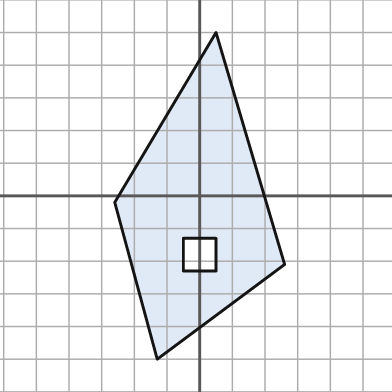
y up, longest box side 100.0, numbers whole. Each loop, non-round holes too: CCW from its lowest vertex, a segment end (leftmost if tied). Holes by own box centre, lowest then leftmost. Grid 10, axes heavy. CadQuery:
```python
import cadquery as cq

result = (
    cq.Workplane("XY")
    .moveTo(-13.0, -50.0)
    .lineTo(26.0, -21.0)
    .lineTo(5.0, 50.0)
    .lineTo(-26.0, -2.0)
    .close()
    .moveTo(-5.0, -23.0)
    .lineTo(5.0, -23.0)
    .lineTo(5.0, -13.0)
    .lineTo(-5.0, -13.0)
    .close()
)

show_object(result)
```